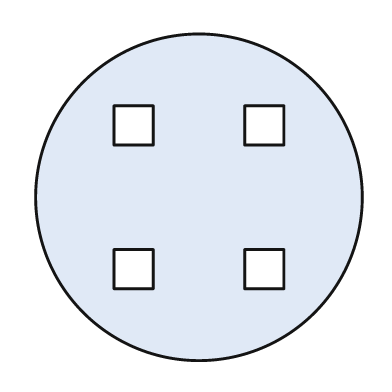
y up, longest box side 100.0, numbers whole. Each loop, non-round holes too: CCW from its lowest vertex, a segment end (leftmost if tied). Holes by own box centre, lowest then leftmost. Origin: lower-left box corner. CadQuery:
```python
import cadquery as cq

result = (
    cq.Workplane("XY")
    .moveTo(50.0, 50.0)
    .circle(50.0)
    .moveTo(24.0, 22.0)
    .lineTo(36.0, 22.0)
    .lineTo(36.0, 34.0)
    .lineTo(24.0, 34.0)
    .close()
    .moveTo(64.0, 22.0)
    .lineTo(76.0, 22.0)
    .lineTo(76.0, 34.0)
    .lineTo(64.0, 34.0)
    .close()
    .moveTo(24.0, 66.0)
    .lineTo(36.0, 66.0)
    .lineTo(36.0, 78.0)
    .lineTo(24.0, 78.0)
    .close()
    .moveTo(64.0, 66.0)
    .lineTo(76.0, 66.0)
    .lineTo(76.0, 78.0)
    .lineTo(64.0, 78.0)
    .close()
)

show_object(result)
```